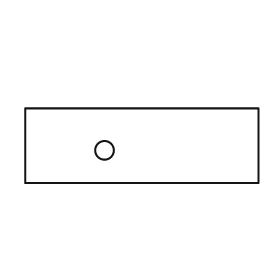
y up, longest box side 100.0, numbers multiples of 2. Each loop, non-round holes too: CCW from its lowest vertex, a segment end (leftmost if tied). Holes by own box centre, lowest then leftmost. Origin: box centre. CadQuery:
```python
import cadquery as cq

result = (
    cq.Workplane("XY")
    .moveTo(-50.0, -16.0)
    .lineTo(50.0, -16.0)
    .lineTo(50.0, 16.0)
    .lineTo(-50.0, 16.0)
    .close()
    .moveTo(-16.0, -2.0)
    .circle(4.0)
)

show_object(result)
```